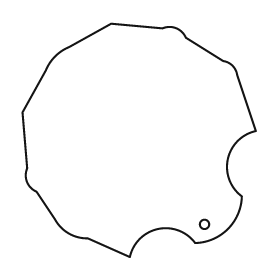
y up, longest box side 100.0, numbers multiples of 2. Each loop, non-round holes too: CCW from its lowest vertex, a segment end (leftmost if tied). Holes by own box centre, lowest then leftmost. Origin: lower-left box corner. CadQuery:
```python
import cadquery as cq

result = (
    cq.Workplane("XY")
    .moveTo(46.0, 0.0)
    .threePointArc((58.0, 12.0), (74.0, 6.0))
    .threePointArc((88.0, 12.0), (94.0, 26.0))
    .threePointArc((88.0, 42.0), (100.0, 54.0))
    .lineTo(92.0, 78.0)
    .threePointArc((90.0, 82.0), (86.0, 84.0))
    .lineTo(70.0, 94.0)
    .threePointArc((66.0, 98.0), (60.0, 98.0))
    .lineTo(38.0, 100.0)
    .lineTo(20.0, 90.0)
    .threePointArc((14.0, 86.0), (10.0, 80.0))
    .lineTo(0.0, 62.0)
    .lineTo(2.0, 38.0)
    .threePointArc((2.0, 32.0), (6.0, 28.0))
    .lineTo(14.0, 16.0)
    .threePointArc((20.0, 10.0), (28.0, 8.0))
    .close()
    .moveTo(78.0, 14.0)
    .circle(2.0)
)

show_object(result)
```